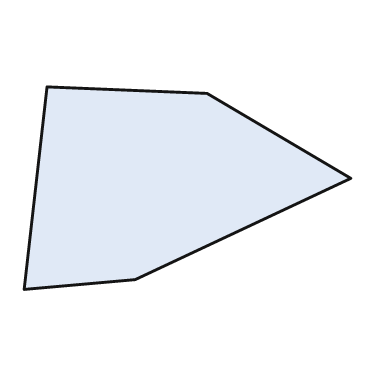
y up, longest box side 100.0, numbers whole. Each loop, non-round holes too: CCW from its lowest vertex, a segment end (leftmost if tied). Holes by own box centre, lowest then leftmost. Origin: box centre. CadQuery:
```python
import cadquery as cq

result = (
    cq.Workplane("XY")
    .moveTo(-50.0, -31.0)
    .lineTo(-16.0, -28.0)
    .lineTo(50.0, 3.0)
    .lineTo(6.0, 29.0)
    .lineTo(-43.0, 31.0)
    .close()
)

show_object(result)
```